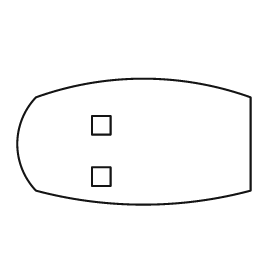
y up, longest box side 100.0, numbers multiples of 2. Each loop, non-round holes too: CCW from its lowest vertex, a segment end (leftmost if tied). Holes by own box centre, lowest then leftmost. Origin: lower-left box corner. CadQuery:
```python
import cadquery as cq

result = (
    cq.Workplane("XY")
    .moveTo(8.0, 6.0)
    .threePointArc((54.0, 0.0), (100.0, 6.0))
    .lineTo(100.0, 46.0)
    .threePointArc((54.0, 54.0), (8.0, 46.0))
    .threePointArc((0.0, 26.0), (8.0, 6.0))
    .close()
    .moveTo(32.0, 8.0)
    .lineTo(40.0, 8.0)
    .lineTo(40.0, 16.0)
    .lineTo(32.0, 16.0)
    .close()
    .moveTo(32.0, 30.0)
    .lineTo(40.0, 30.0)
    .lineTo(40.0, 38.0)
    .lineTo(32.0, 38.0)
    .close()
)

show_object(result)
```